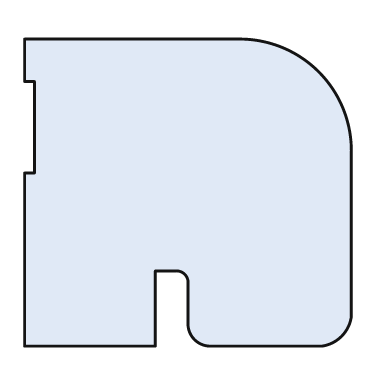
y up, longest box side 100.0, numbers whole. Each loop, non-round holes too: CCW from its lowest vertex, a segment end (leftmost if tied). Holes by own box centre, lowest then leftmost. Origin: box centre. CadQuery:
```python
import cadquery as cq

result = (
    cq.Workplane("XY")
    .moveTo(-50.0, -47.0)
    .lineTo(-10.0, -47.0)
    .lineTo(-10.0, -24.0)
    .lineTo(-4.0, -24.0)
    .threePointArc((-1.0, -25.0), (0.0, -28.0))
    .lineTo(0.0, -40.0)
    .threePointArc((2.0, -45.0), (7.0, -47.0))
    .lineTo(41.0, -47.0)
    .threePointArc((47.0, -44.0), (50.0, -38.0))
    .lineTo(50.0, 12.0)
    .threePointArc((40.0, 37.0), (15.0, 47.0))
    .lineTo(-50.0, 47.0)
    .lineTo(-50.0, 34.0)
    .lineTo(-47.0, 34.0)
    .lineTo(-47.0, 6.0)
    .lineTo(-50.0, 6.0)
    .close()
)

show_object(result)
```